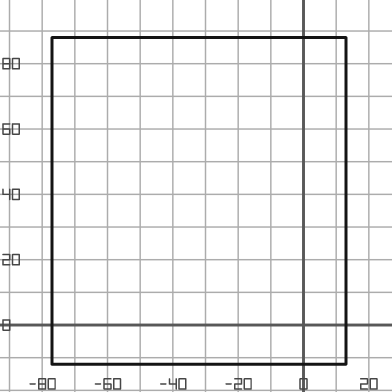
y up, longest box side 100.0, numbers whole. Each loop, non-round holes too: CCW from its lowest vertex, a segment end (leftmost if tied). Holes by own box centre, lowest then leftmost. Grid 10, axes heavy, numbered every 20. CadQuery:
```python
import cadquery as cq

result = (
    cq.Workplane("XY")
    .moveTo(-77.0, -12.0)
    .lineTo(13.0, -12.0)
    .lineTo(13.0, 88.0)
    .lineTo(-77.0, 88.0)
    .close()
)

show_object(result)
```